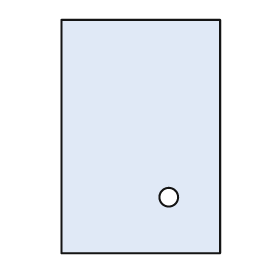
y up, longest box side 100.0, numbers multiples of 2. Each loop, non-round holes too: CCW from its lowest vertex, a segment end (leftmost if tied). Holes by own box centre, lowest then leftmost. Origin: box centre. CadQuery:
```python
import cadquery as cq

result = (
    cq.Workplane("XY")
    .moveTo(-34.0, -50.0)
    .lineTo(34.0, -50.0)
    .lineTo(34.0, 50.0)
    .lineTo(-34.0, 50.0)
    .close()
    .moveTo(12.0, -26.0)
    .circle(4.0)
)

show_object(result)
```